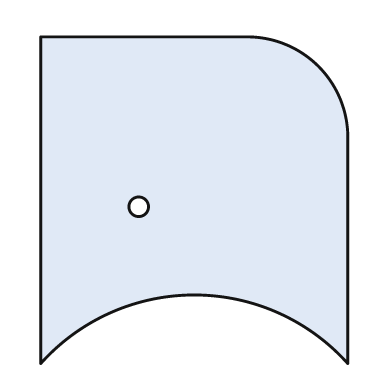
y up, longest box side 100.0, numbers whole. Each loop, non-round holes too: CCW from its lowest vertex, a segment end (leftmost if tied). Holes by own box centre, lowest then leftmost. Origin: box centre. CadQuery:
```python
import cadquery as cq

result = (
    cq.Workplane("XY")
    .moveTo(-47.0, -50.0)
    .threePointArc((0.0, -29.0), (47.0, -50.0))
    .lineTo(47.0, 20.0)
    .threePointArc((38.0, 41.0), (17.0, 50.0))
    .lineTo(-47.0, 50.0)
    .close()
    .moveTo(-17.0, -2.0)
    .circle(3.0)
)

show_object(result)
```